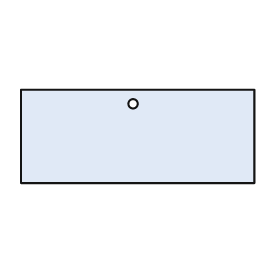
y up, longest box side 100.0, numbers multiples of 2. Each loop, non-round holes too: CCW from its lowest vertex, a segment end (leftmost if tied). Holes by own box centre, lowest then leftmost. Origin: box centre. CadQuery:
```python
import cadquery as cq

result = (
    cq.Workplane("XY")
    .moveTo(-50.0, -20.0)
    .lineTo(50.0, -20.0)
    .lineTo(50.0, 20.0)
    .lineTo(-50.0, 20.0)
    .close()
    .moveTo(-2.0, 14.0)
    .circle(2.0)
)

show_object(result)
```